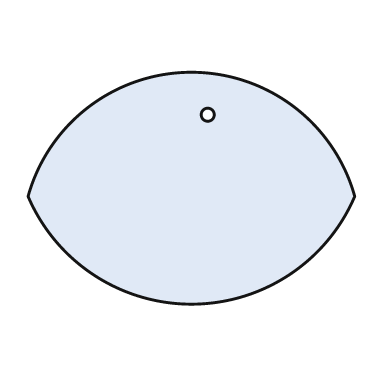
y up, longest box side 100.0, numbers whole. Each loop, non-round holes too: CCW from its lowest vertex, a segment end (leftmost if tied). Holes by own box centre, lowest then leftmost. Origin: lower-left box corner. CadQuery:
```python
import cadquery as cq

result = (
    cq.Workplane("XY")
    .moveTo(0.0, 33.0)
    .threePointArc((50.0, 0.0), (100.0, 33.0))
    .threePointArc((50.0, 71.0), (0.0, 33.0))
    .close()
    .moveTo(55.0, 58.0)
    .circle(2.0)
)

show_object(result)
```